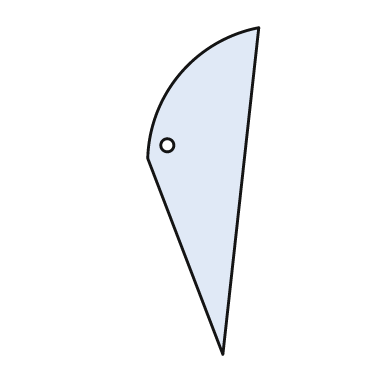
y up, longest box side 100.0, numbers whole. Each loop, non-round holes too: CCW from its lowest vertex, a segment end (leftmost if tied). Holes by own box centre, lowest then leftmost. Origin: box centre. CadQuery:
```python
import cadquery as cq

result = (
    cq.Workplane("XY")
    .moveTo(6.0, -50.0)
    .lineTo(17.0, 50.0)
    .threePointArc((-7.0, 36.0), (-17.0, 10.0))
    .close()
    .moveTo(-11.0, 14.0)
    .circle(2.0)
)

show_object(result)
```